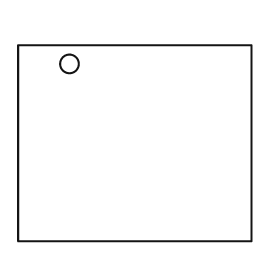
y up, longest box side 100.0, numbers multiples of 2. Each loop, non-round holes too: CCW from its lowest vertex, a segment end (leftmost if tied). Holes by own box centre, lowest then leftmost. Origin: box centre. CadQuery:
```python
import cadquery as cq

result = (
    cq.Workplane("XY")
    .moveTo(-50.0, -42.0)
    .lineTo(50.0, -42.0)
    .lineTo(50.0, 42.0)
    .lineTo(-50.0, 42.0)
    .close()
    .moveTo(-28.0, 34.0)
    .circle(4.0)
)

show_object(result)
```